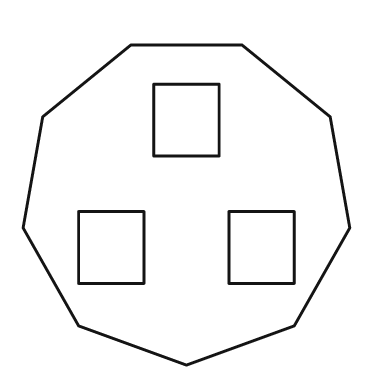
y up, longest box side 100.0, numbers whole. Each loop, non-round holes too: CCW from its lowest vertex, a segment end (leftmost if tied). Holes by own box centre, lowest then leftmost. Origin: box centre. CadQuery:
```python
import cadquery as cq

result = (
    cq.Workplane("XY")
    .moveTo(0.0, -49.0)
    .lineTo(33.0, -37.0)
    .lineTo(50.0, -7.0)
    .lineTo(44.0, 27.0)
    .lineTo(17.0, 49.0)
    .lineTo(-17.0, 49.0)
    .lineTo(-44.0, 27.0)
    .lineTo(-50.0, -7.0)
    .lineTo(-33.0, -37.0)
    .close()
    .moveTo(-33.0, -24.0)
    .lineTo(-13.0, -24.0)
    .lineTo(-13.0, -2.0)
    .lineTo(-33.0, -2.0)
    .close()
    .moveTo(13.0, -24.0)
    .lineTo(33.0, -24.0)
    .lineTo(33.0, -2.0)
    .lineTo(13.0, -2.0)
    .close()
    .moveTo(-10.0, 15.0)
    .lineTo(10.0, 15.0)
    .lineTo(10.0, 37.0)
    .lineTo(-10.0, 37.0)
    .close()
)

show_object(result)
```